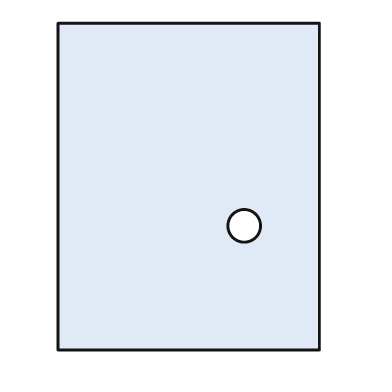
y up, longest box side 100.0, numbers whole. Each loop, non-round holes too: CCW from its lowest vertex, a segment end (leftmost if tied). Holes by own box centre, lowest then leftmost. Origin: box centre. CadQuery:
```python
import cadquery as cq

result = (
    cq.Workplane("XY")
    .moveTo(-40.0, -50.0)
    .lineTo(40.0, -50.0)
    .lineTo(40.0, 50.0)
    .lineTo(-40.0, 50.0)
    .close()
    .moveTo(17.0, -12.0)
    .circle(5.0)
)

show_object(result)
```